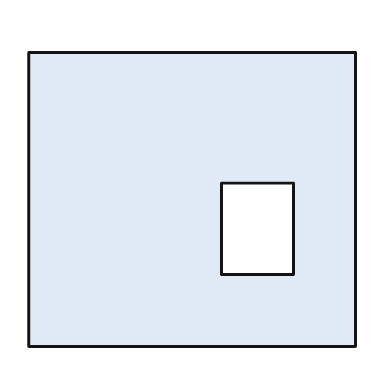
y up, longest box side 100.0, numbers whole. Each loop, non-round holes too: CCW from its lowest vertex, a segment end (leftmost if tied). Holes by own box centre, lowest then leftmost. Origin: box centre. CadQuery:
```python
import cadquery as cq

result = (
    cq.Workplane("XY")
    .moveTo(-50.0, -45.0)
    .lineTo(50.0, -45.0)
    .lineTo(50.0, 45.0)
    .lineTo(-50.0, 45.0)
    .close()
    .moveTo(9.0, -23.0)
    .lineTo(31.0, -23.0)
    .lineTo(31.0, 5.0)
    .lineTo(9.0, 5.0)
    .close()
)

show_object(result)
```